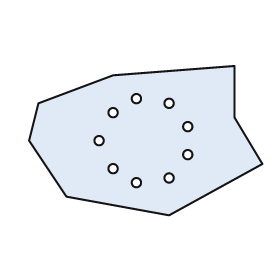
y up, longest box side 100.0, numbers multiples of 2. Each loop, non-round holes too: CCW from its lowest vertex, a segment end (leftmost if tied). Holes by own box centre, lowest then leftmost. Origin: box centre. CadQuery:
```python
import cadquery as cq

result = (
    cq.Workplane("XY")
    .moveTo(10.0, -32.0)
    .lineTo(50.0, -10.0)
    .lineTo(38.0, 10.0)
    .lineTo(38.0, 32.0)
    .lineTo(-14.0, 28.0)
    .lineTo(-46.0, 16.0)
    .lineTo(-50.0, 0.0)
    .lineTo(-34.0, -24.0)
    .close()
    .moveTo(-4.0, -18.0)
    .circle(2.0)
    .moveTo(10.0, -16.0)
    .circle(2.0)
    .moveTo(-14.0, -12.0)
    .circle(2.0)
    .moveTo(18.0, -6.0)
    .circle(2.0)
    .moveTo(-20.0, 0.0)
    .circle(2.0)
    .moveTo(18.0, 6.0)
    .circle(2.0)
    .moveTo(-14.0, 12.0)
    .circle(2.0)
    .moveTo(10.0, 16.0)
    .circle(2.0)
    .moveTo(-4.0, 18.0)
    .circle(2.0)
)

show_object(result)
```